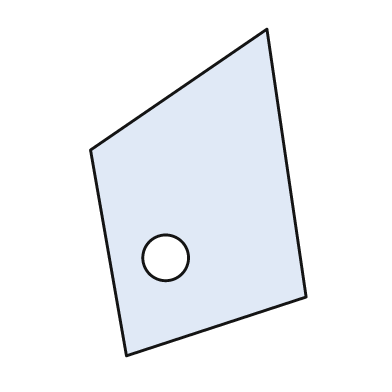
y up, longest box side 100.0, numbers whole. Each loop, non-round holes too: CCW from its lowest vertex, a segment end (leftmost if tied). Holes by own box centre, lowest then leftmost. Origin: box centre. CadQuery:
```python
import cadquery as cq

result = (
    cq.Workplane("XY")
    .moveTo(-22.0, -50.0)
    .lineTo(33.0, -32.0)
    .lineTo(21.0, 50.0)
    .lineTo(-33.0, 13.0)
    .close()
    .moveTo(-10.0, -20.0)
    .circle(7.0)
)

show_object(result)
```